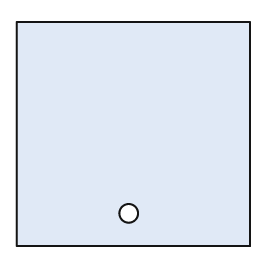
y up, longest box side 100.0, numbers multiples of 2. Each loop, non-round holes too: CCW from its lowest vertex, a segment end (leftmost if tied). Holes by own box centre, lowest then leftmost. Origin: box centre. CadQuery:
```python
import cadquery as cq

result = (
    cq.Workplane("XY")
    .moveTo(-50.0, -48.0)
    .lineTo(50.0, -48.0)
    .lineTo(50.0, 48.0)
    .lineTo(-50.0, 48.0)
    .close()
    .moveTo(-2.0, -34.0)
    .circle(4.0)
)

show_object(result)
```